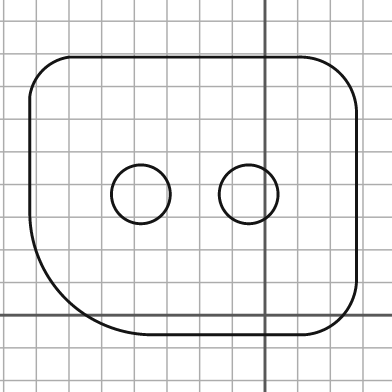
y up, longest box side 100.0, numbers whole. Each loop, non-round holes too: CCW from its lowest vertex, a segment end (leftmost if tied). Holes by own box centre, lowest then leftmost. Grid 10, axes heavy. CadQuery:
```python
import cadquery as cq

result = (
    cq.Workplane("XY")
    .moveTo(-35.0, -6.0)
    .lineTo(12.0, -6.0)
    .threePointArc((23.0, -1.0), (28.0, 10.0))
    .lineTo(28.0, 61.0)
    .threePointArc((23.0, 74.0), (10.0, 79.0))
    .lineTo(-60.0, 79.0)
    .threePointArc((-68.0, 75.0), (-72.0, 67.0))
    .lineTo(-72.0, 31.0)
    .threePointArc((-61.0, 5.0), (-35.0, -6.0))
    .close()
    .moveTo(-38.0, 37.0)
    .circle(9.0)
    .moveTo(-5.0, 37.0)
    .circle(9.0)
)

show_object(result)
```